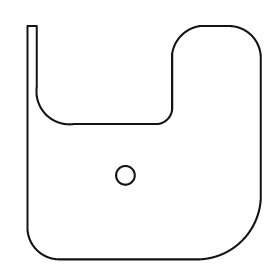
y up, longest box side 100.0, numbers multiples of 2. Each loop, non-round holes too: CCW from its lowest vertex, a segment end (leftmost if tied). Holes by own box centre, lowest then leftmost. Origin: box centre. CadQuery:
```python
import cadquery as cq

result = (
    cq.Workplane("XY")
    .moveTo(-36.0, -50.0)
    .lineTo(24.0, -50.0)
    .threePointArc((42.0, -42.0), (50.0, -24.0))
    .lineTo(50.0, 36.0)
    .threePointArc((46.0, 46.0), (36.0, 50.0))
    .lineTo(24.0, 50.0)
    .threePointArc((16.0, 46.0), (12.0, 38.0))
    .lineTo(12.0, 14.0)
    .threePointArc((10.0, 10.0), (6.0, 8.0))
    .lineTo(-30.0, 8.0)
    .threePointArc((-42.0, 12.0), (-46.0, 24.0))
    .lineTo(-46.0, 50.0)
    .lineTo(-50.0, 50.0)
    .lineTo(-50.0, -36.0)
    .threePointArc((-46.0, -46.0), (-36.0, -50.0))
    .close()
    .moveTo(-8.0, -14.0)
    .circle(4.0)
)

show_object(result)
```